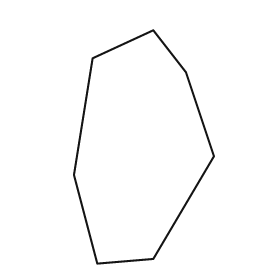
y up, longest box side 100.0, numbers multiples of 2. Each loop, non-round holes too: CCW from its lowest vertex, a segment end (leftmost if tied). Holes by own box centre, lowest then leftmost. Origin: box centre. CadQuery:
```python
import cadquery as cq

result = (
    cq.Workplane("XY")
    .moveTo(-20.0, -50.0)
    .lineTo(4.0, -48.0)
    .lineTo(30.0, -4.0)
    .lineTo(18.0, 32.0)
    .lineTo(4.0, 50.0)
    .lineTo(-22.0, 38.0)
    .lineTo(-30.0, -12.0)
    .close()
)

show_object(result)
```